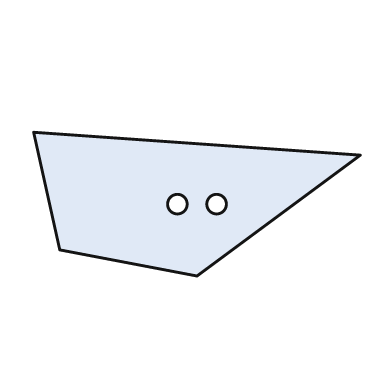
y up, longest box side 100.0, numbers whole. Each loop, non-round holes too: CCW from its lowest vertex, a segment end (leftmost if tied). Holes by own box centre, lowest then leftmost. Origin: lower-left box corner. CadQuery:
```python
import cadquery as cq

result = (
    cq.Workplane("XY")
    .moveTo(50.0, 0.0)
    .lineTo(100.0, 37.0)
    .lineTo(0.0, 44.0)
    .lineTo(8.0, 8.0)
    .close()
    .moveTo(44.0, 22.0)
    .circle(3.0)
    .moveTo(56.0, 22.0)
    .circle(3.0)
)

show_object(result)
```